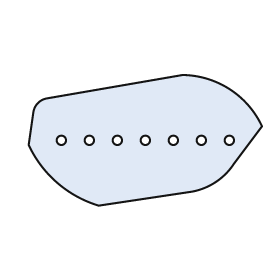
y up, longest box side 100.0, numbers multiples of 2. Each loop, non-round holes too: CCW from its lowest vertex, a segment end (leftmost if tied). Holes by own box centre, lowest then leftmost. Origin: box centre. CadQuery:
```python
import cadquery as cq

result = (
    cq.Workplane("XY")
    .moveTo(-20.0, -28.0)
    .lineTo(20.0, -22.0)
    .threePointArc((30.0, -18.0), (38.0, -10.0))
    .lineTo(50.0, 6.0)
    .threePointArc((36.0, 22.0), (16.0, 28.0))
    .lineTo(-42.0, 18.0)
    .threePointArc((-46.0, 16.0), (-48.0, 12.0))
    .lineTo(-50.0, -2.0)
    .threePointArc((-38.0, -18.0), (-20.0, -28.0))
    .close()
    .moveTo(-36.0, 0.0)
    .circle(2.0)
    .moveTo(-24.0, 0.0)
    .circle(2.0)
    .moveTo(-12.0, 0.0)
    .circle(2.0)
    .moveTo(0.0, 0.0)
    .circle(2.0)
    .moveTo(12.0, 0.0)
    .circle(2.0)
    .moveTo(24.0, 0.0)
    .circle(2.0)
    .moveTo(36.0, 0.0)
    .circle(2.0)
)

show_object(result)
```